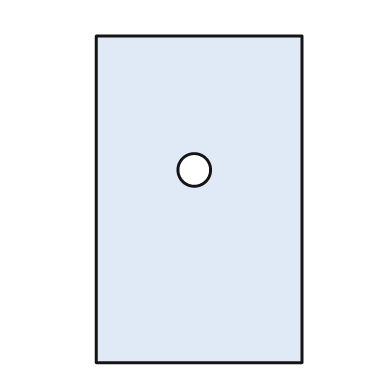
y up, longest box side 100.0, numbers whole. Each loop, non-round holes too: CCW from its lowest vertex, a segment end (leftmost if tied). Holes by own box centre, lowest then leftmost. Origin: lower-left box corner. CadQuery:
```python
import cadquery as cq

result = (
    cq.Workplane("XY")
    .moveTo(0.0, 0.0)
    .lineTo(63.0, 0.0)
    .lineTo(63.0, 100.0)
    .lineTo(0.0, 100.0)
    .close()
    .moveTo(30.0, 59.0)
    .circle(5.0)
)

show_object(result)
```